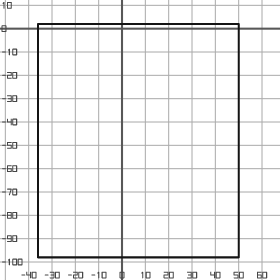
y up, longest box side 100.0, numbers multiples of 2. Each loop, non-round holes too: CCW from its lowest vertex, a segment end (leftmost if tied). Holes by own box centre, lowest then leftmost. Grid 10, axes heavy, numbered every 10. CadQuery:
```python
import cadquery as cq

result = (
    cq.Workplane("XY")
    .moveTo(-36.0, -98.0)
    .lineTo(50.0, -98.0)
    .lineTo(50.0, 2.0)
    .lineTo(-36.0, 2.0)
    .close()
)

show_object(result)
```